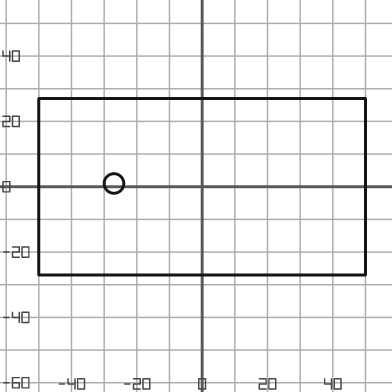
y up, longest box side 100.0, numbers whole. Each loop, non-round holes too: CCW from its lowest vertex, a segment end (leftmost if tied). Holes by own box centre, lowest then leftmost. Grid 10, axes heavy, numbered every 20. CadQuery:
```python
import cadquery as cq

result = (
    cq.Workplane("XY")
    .moveTo(-50.0, -27.0)
    .lineTo(50.0, -27.0)
    .lineTo(50.0, 27.0)
    .lineTo(-50.0, 27.0)
    .close()
    .moveTo(-27.0, 1.0)
    .circle(3.0)
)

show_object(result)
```